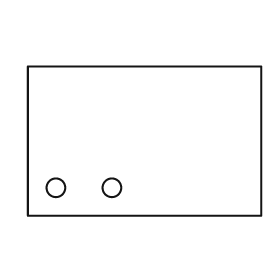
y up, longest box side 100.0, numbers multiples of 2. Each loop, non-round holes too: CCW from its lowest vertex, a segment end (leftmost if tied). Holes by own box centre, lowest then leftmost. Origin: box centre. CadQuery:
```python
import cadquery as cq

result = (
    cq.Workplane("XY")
    .moveTo(-50.0, -32.0)
    .lineTo(50.0, -32.0)
    .lineTo(50.0, 32.0)
    .lineTo(-50.0, 32.0)
    .close()
    .moveTo(-38.0, -20.0)
    .circle(4.0)
    .moveTo(-14.0, -20.0)
    .circle(4.0)
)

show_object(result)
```